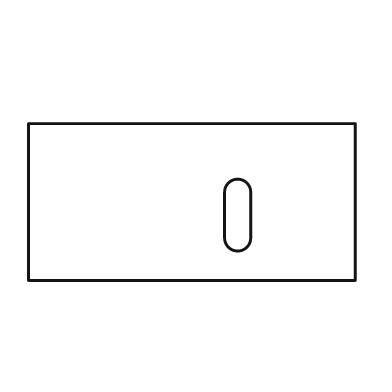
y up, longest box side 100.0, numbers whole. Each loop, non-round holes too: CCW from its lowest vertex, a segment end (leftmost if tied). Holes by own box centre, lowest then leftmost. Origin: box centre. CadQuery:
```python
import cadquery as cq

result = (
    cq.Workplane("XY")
    .moveTo(-50.0, -24.0)
    .lineTo(50.0, -24.0)
    .lineTo(50.0, 24.0)
    .lineTo(-50.0, 24.0)
    .close()
    .moveTo(10.0, -11.0)
    .threePointArc((14.0, -15.0), (18.0, -11.0))
    .lineTo(18.0, 3.0)
    .threePointArc((14.0, 7.0), (10.0, 3.0))
    .close()
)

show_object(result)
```